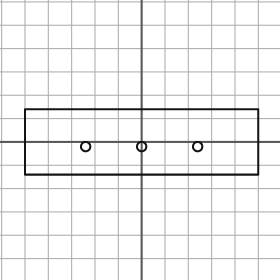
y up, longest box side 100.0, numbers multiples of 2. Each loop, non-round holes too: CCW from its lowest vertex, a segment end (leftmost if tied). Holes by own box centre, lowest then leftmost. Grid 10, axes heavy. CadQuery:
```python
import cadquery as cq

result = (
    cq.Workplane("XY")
    .moveTo(-50.0, -14.0)
    .lineTo(50.0, -14.0)
    .lineTo(50.0, 14.0)
    .lineTo(-50.0, 14.0)
    .close()
    .moveTo(-24.0, -2.0)
    .circle(2.0)
    .moveTo(0.0, -2.0)
    .circle(2.0)
    .moveTo(24.0, -2.0)
    .circle(2.0)
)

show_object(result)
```